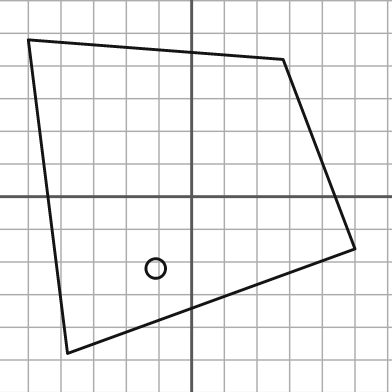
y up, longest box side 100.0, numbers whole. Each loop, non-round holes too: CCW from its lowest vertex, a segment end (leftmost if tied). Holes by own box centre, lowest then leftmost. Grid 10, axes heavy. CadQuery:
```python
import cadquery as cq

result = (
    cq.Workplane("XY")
    .moveTo(-38.0, -48.0)
    .lineTo(50.0, -16.0)
    .lineTo(28.0, 42.0)
    .lineTo(-50.0, 48.0)
    .close()
    .moveTo(-11.0, -22.0)
    .circle(3.0)
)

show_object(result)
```